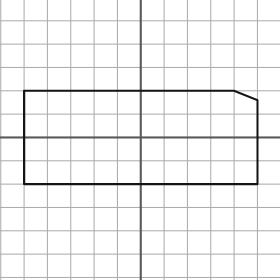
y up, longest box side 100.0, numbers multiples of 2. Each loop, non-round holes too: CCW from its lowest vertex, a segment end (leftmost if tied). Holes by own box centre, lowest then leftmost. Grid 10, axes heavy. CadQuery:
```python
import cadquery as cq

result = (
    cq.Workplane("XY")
    .moveTo(-50.0, -20.0)
    .lineTo(50.0, -20.0)
    .lineTo(50.0, 16.0)
    .lineTo(40.0, 20.0)
    .lineTo(-50.0, 20.0)
    .close()
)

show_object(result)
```